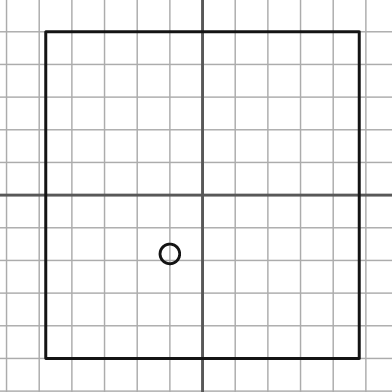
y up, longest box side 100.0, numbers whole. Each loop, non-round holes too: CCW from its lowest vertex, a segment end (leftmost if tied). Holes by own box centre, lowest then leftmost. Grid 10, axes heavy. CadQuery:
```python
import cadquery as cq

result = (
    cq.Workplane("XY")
    .moveTo(-48.0, -50.0)
    .lineTo(48.0, -50.0)
    .lineTo(48.0, 50.0)
    .lineTo(-48.0, 50.0)
    .close()
    .moveTo(-10.0, -18.0)
    .circle(3.0)
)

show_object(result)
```